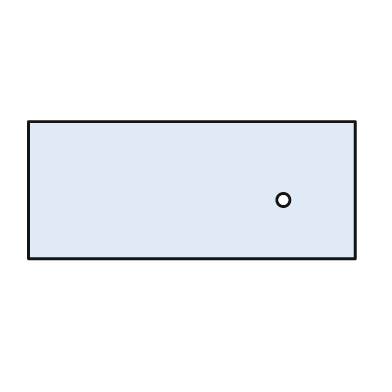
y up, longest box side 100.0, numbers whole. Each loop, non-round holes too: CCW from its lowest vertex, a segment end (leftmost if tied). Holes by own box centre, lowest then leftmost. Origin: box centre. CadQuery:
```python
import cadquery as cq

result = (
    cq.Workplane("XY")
    .moveTo(-50.0, -21.0)
    .lineTo(50.0, -21.0)
    .lineTo(50.0, 21.0)
    .lineTo(-50.0, 21.0)
    .close()
    .moveTo(28.0, -3.0)
    .circle(2.0)
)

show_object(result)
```